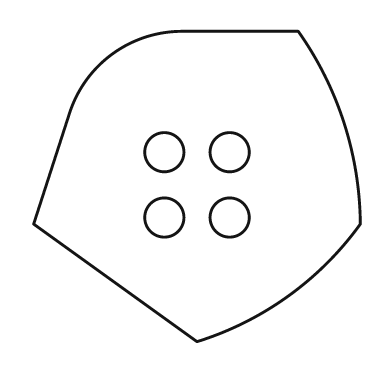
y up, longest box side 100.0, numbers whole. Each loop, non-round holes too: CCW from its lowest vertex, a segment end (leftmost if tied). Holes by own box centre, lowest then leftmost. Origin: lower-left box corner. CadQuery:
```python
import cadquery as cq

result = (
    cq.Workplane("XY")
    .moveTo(50.0, 0.0)
    .threePointArc((78.0, 14.0), (100.0, 36.0))
    .threePointArc((95.0, 67.0), (81.0, 95.0))
    .lineTo(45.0, 95.0)
    .threePointArc((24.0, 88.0), (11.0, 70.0))
    .lineTo(0.0, 36.0)
    .close()
    .moveTo(40.0, 38.0)
    .circle(6.0)
    .moveTo(60.0, 38.0)
    .circle(6.0)
    .moveTo(40.0, 58.0)
    .circle(6.0)
    .moveTo(60.0, 58.0)
    .circle(6.0)
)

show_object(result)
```